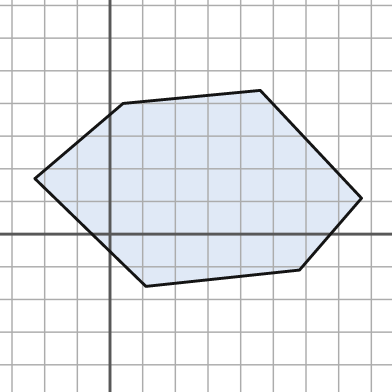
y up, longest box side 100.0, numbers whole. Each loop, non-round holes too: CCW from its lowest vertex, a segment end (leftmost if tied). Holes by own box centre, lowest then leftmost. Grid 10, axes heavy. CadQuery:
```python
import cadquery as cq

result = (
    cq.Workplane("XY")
    .moveTo(11.0, -16.0)
    .lineTo(58.0, -11.0)
    .lineTo(77.0, 11.0)
    .lineTo(46.0, 44.0)
    .lineTo(4.0, 40.0)
    .lineTo(-23.0, 17.0)
    .close()
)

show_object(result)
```